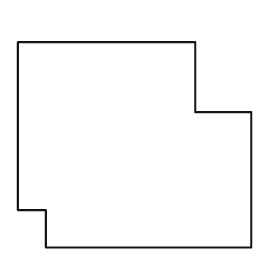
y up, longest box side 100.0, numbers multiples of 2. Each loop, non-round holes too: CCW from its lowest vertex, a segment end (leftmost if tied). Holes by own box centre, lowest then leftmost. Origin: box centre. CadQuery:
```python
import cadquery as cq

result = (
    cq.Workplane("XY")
    .moveTo(-38.0, -44.0)
    .lineTo(50.0, -44.0)
    .lineTo(50.0, 14.0)
    .lineTo(26.0, 14.0)
    .lineTo(26.0, 44.0)
    .lineTo(-50.0, 44.0)
    .lineTo(-50.0, -28.0)
    .lineTo(-38.0, -28.0)
    .close()
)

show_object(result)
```